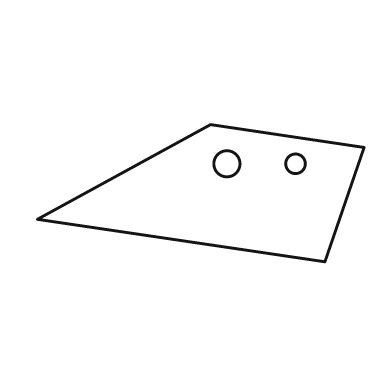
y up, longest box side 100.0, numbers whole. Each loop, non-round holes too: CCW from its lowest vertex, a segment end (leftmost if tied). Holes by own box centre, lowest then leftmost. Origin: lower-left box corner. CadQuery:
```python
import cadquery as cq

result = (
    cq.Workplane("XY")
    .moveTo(88.0, 0.0)
    .lineTo(100.0, 35.0)
    .lineTo(53.0, 42.0)
    .lineTo(0.0, 13.0)
    .close()
    .moveTo(58.0, 30.0)
    .circle(4.0)
    .moveTo(79.0, 30.0)
    .circle(3.0)
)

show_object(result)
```